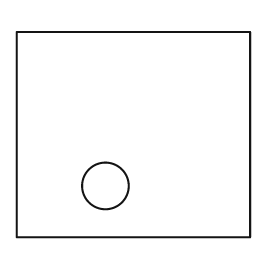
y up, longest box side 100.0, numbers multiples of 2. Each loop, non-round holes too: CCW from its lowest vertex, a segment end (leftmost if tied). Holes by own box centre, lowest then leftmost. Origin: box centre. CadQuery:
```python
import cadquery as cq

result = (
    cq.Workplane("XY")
    .moveTo(-50.0, -44.0)
    .lineTo(50.0, -44.0)
    .lineTo(50.0, 44.0)
    .lineTo(-50.0, 44.0)
    .close()
    .moveTo(-12.0, -22.0)
    .circle(10.0)
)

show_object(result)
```